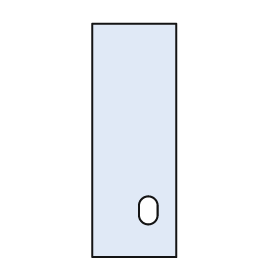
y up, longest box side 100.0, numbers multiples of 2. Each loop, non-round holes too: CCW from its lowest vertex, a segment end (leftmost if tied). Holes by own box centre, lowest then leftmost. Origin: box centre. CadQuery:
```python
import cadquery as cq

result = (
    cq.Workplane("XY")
    .moveTo(-18.0, -50.0)
    .lineTo(18.0, -50.0)
    .lineTo(18.0, 50.0)
    .lineTo(-18.0, 50.0)
    .close()
    .moveTo(2.0, -32.0)
    .threePointArc((6.0, -36.0), (10.0, -32.0))
    .lineTo(10.0, -28.0)
    .threePointArc((6.0, -24.0), (2.0, -28.0))
    .close()
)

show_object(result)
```